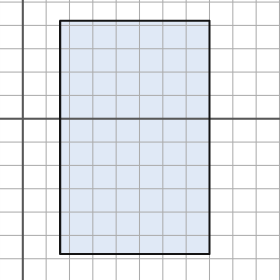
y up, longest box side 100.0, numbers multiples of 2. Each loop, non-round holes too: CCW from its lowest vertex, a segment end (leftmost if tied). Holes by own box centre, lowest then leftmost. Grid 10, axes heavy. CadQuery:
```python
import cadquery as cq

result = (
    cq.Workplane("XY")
    .moveTo(16.0, -58.0)
    .lineTo(80.0, -58.0)
    .lineTo(80.0, 42.0)
    .lineTo(16.0, 42.0)
    .close()
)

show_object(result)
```